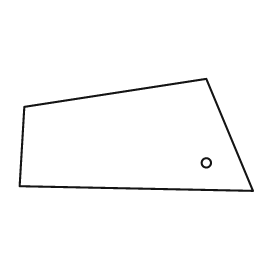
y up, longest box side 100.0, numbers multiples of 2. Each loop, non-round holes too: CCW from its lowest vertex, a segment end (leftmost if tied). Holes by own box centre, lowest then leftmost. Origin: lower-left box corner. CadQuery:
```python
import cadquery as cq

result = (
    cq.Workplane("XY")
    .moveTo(100.0, 0.0)
    .lineTo(80.0, 48.0)
    .lineTo(2.0, 36.0)
    .lineTo(0.0, 2.0)
    .close()
    .moveTo(80.0, 12.0)
    .circle(2.0)
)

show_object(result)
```